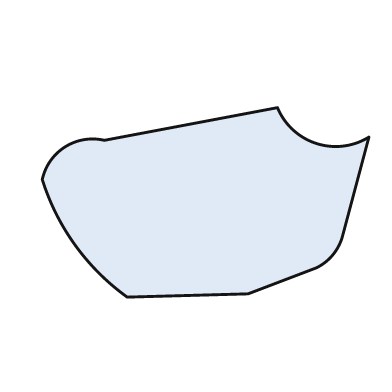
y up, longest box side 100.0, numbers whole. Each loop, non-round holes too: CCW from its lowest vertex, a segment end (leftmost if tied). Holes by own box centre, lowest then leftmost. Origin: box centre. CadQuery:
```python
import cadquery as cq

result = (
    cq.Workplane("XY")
    .moveTo(-24.0, -29.0)
    .lineTo(13.0, -28.0)
    .lineTo(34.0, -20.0)
    .threePointArc((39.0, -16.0), (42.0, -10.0))
    .lineTo(50.0, 20.0)
    .threePointArc((34.0, 18.0), (22.0, 29.0))
    .lineTo(-31.0, 19.0)
    .threePointArc((-43.0, 17.0), (-50.0, 7.0))
    .threePointArc((-40.0, -13.0), (-24.0, -29.0))
    .close()
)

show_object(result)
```